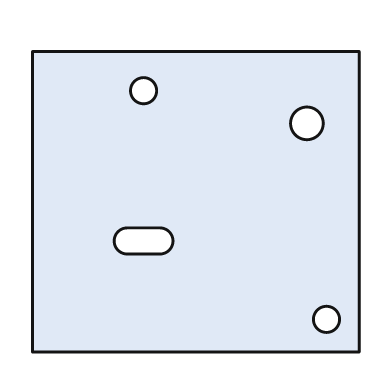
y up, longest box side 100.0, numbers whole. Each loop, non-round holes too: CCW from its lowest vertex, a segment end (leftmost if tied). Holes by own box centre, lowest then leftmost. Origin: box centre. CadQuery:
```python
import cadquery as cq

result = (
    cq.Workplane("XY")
    .moveTo(-50.0, -46.0)
    .lineTo(50.0, -46.0)
    .lineTo(50.0, 46.0)
    .lineTo(-50.0, 46.0)
    .close()
    .moveTo(40.0, -36.0)
    .circle(4.0)
    .moveTo(-21.0, -16.0)
    .lineTo(-11.0, -16.0)
    .threePointArc((-7.0, -12.0), (-11.0, -8.0))
    .lineTo(-21.0, -8.0)
    .threePointArc((-25.0, -12.0), (-21.0, -16.0))
    .close()
    .moveTo(34.0, 24.0)
    .circle(5.0)
    .moveTo(-16.0, 34.0)
    .circle(4.0)
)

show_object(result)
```